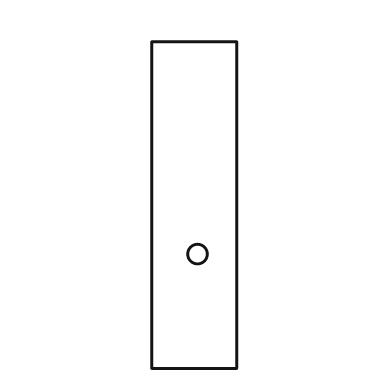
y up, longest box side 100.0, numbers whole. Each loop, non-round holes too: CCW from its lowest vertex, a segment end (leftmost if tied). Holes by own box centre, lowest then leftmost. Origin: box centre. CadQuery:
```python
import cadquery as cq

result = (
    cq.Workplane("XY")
    .moveTo(-13.0, -50.0)
    .lineTo(13.0, -50.0)
    .lineTo(13.0, 50.0)
    .lineTo(-13.0, 50.0)
    .close()
    .moveTo(1.0, -15.0)
    .circle(3.0)
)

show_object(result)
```